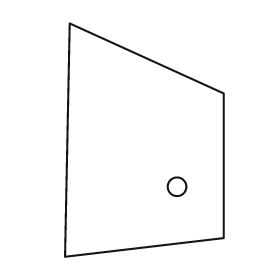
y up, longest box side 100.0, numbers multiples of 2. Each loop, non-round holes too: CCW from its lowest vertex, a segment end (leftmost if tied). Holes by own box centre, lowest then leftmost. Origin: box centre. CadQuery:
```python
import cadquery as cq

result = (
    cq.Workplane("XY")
    .moveTo(-34.0, -50.0)
    .lineTo(34.0, -42.0)
    .lineTo(34.0, 20.0)
    .lineTo(-32.0, 50.0)
    .close()
    .moveTo(14.0, -20.0)
    .circle(4.0)
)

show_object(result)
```